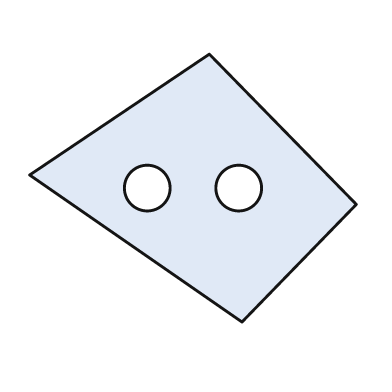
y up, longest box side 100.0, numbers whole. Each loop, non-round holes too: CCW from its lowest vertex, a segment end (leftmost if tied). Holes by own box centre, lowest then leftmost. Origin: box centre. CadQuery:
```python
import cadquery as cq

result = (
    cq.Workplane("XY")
    .moveTo(15.0, -41.0)
    .lineTo(50.0, -5.0)
    .lineTo(5.0, 41.0)
    .lineTo(-50.0, 4.0)
    .close()
    .moveTo(-14.0, 0.0)
    .circle(7.0)
    .moveTo(14.0, 0.0)
    .circle(7.0)
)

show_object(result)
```